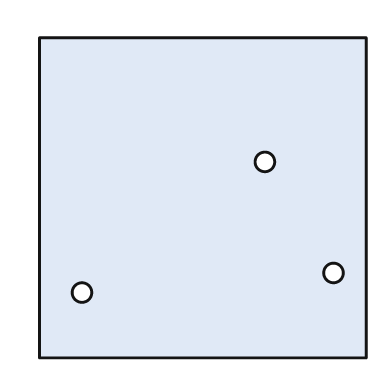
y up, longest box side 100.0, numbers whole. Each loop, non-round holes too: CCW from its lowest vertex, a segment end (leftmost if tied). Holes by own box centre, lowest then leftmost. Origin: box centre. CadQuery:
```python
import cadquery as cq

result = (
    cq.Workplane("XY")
    .moveTo(-50.0, -49.0)
    .lineTo(50.0, -49.0)
    .lineTo(50.0, 49.0)
    .lineTo(-50.0, 49.0)
    .close()
    .moveTo(-37.0, -29.0)
    .circle(3.0)
    .moveTo(40.0, -23.0)
    .circle(3.0)
    .moveTo(19.0, 11.0)
    .circle(3.0)
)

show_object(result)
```